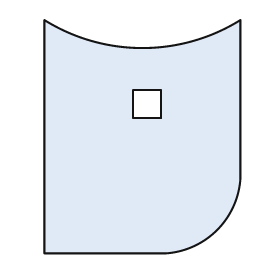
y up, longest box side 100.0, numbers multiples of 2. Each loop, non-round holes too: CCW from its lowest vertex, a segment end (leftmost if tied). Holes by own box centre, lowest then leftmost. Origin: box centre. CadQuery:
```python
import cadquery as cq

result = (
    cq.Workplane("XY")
    .moveTo(-42.0, -50.0)
    .lineTo(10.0, -50.0)
    .threePointArc((32.0, -40.0), (42.0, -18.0))
    .lineTo(42.0, 50.0)
    .threePointArc((0.0, 38.0), (-42.0, 50.0))
    .close()
    .moveTo(-4.0, 8.0)
    .lineTo(8.0, 8.0)
    .lineTo(8.0, 20.0)
    .lineTo(-4.0, 20.0)
    .close()
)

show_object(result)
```